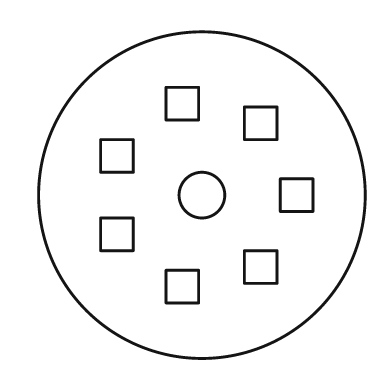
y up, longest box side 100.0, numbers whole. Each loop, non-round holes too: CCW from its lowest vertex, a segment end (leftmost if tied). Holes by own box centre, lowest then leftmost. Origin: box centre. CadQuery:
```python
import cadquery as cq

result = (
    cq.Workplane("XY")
    .moveTo(0.0, 0.0)
    .circle(50.0)
    .moveTo(-11.0, -33.0)
    .lineTo(-1.0, -33.0)
    .lineTo(-1.0, -23.0)
    .lineTo(-11.0, -23.0)
    .close()
    .moveTo(13.0, -27.0)
    .lineTo(23.0, -27.0)
    .lineTo(23.0, -17.0)
    .lineTo(13.0, -17.0)
    .close()
    .moveTo(-31.0, -17.0)
    .lineTo(-21.0, -17.0)
    .lineTo(-21.0, -7.0)
    .lineTo(-31.0, -7.0)
    .close()
    .moveTo(0.0, 0.0)
    .circle(7.0)
    .moveTo(24.0, -5.0)
    .lineTo(34.0, -5.0)
    .lineTo(34.0, 5.0)
    .lineTo(24.0, 5.0)
    .close()
    .moveTo(-31.0, 7.0)
    .lineTo(-21.0, 7.0)
    .lineTo(-21.0, 17.0)
    .lineTo(-31.0, 17.0)
    .close()
    .moveTo(13.0, 17.0)
    .lineTo(23.0, 17.0)
    .lineTo(23.0, 27.0)
    .lineTo(13.0, 27.0)
    .close()
    .moveTo(-11.0, 23.0)
    .lineTo(-1.0, 23.0)
    .lineTo(-1.0, 33.0)
    .lineTo(-11.0, 33.0)
    .close()
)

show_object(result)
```